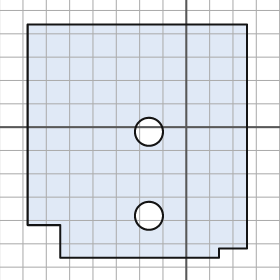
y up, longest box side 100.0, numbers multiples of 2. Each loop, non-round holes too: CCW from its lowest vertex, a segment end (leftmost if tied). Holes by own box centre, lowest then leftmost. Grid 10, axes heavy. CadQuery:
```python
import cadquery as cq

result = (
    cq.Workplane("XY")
    .moveTo(-54.0, -56.0)
    .lineTo(14.0, -56.0)
    .lineTo(14.0, -52.0)
    .lineTo(26.0, -52.0)
    .lineTo(26.0, 44.0)
    .lineTo(-68.0, 44.0)
    .lineTo(-68.0, -42.0)
    .lineTo(-54.0, -42.0)
    .close()
    .moveTo(-16.0, -38.0)
    .circle(6.0)
    .moveTo(-16.0, -2.0)
    .circle(6.0)
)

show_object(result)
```